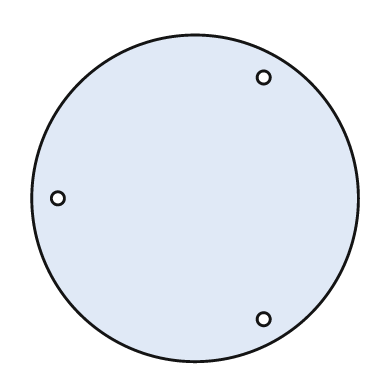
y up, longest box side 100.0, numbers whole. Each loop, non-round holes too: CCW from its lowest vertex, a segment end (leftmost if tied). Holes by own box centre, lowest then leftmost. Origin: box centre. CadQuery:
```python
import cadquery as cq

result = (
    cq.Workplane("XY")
    .moveTo(0.0, 0.0)
    .circle(50.0)
    .moveTo(21.0, -37.0)
    .circle(2.0)
    .moveTo(-42.0, 0.0)
    .circle(2.0)
    .moveTo(21.0, 37.0)
    .circle(2.0)
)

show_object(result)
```